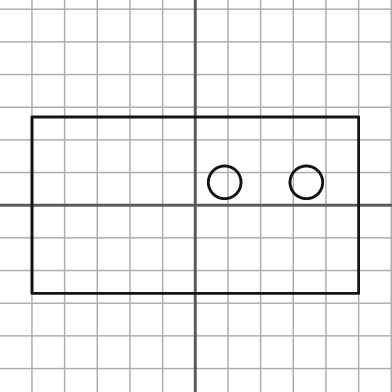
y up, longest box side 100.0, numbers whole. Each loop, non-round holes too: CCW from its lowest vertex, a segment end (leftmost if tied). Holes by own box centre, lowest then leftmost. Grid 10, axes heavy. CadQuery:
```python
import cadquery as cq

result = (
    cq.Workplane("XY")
    .moveTo(-50.0, -27.0)
    .lineTo(50.0, -27.0)
    .lineTo(50.0, 27.0)
    .lineTo(-50.0, 27.0)
    .close()
    .moveTo(9.0, 7.0)
    .circle(5.0)
    .moveTo(34.0, 7.0)
    .circle(5.0)
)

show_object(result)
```